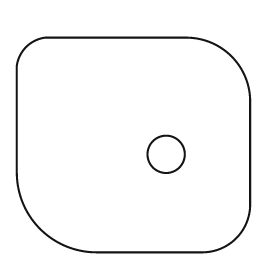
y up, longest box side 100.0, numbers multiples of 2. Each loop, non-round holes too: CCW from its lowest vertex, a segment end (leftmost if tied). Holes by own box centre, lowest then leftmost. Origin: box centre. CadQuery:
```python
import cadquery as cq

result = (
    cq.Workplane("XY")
    .moveTo(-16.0, -46.0)
    .lineTo(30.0, -46.0)
    .threePointArc((44.0, -40.0), (50.0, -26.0))
    .lineTo(50.0, 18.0)
    .threePointArc((42.0, 38.0), (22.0, 46.0))
    .lineTo(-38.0, 46.0)
    .threePointArc((-46.0, 42.0), (-50.0, 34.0))
    .lineTo(-50.0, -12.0)
    .threePointArc((-40.0, -36.0), (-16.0, -46.0))
    .close()
    .moveTo(14.0, -4.0)
    .circle(8.0)
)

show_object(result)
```